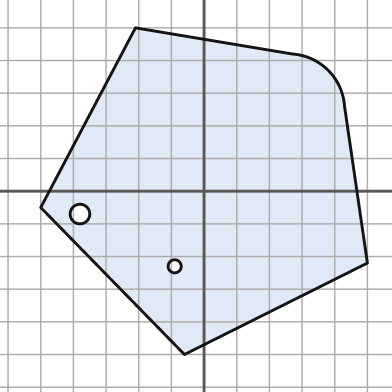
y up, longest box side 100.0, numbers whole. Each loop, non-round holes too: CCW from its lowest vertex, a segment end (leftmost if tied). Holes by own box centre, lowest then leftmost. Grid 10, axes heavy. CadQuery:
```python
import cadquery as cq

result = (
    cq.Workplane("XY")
    .moveTo(-6.0, -50.0)
    .lineTo(50.0, -22.0)
    .lineTo(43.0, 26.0)
    .threePointArc((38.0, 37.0), (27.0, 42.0))
    .lineTo(-21.0, 50.0)
    .lineTo(-50.0, -5.0)
    .close()
    .moveTo(-9.0, -23.0)
    .circle(2.0)
    .moveTo(-38.0, -7.0)
    .circle(3.0)
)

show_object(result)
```